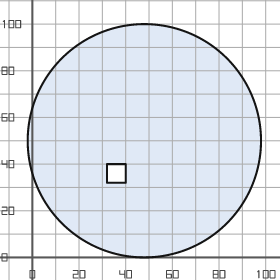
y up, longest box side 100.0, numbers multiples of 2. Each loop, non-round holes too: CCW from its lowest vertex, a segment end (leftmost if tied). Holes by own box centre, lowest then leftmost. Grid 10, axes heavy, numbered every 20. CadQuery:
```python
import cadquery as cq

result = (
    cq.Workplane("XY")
    .moveTo(48.0, 50.0)
    .circle(50.0)
    .moveTo(32.0, 32.0)
    .lineTo(40.0, 32.0)
    .lineTo(40.0, 40.0)
    .lineTo(32.0, 40.0)
    .close()
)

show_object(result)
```